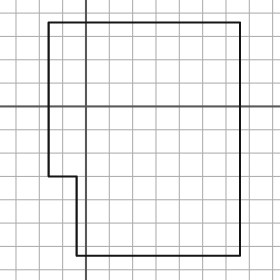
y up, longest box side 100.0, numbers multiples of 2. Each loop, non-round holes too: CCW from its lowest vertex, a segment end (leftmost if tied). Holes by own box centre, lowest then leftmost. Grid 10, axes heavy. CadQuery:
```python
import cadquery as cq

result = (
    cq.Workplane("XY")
    .moveTo(-4.0, -64.0)
    .lineTo(66.0, -64.0)
    .lineTo(66.0, 36.0)
    .lineTo(-16.0, 36.0)
    .lineTo(-16.0, -30.0)
    .lineTo(-4.0, -30.0)
    .close()
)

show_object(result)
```